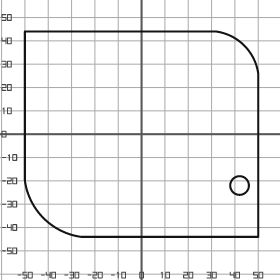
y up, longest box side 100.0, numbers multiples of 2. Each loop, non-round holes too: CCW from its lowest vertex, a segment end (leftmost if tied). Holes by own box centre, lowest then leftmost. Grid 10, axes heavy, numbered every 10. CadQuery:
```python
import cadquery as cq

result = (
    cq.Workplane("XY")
    .moveTo(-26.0, -44.0)
    .lineTo(50.0, -44.0)
    .lineTo(50.0, 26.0)
    .threePointArc((44.0, 38.0), (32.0, 44.0))
    .lineTo(-50.0, 44.0)
    .lineTo(-50.0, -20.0)
    .threePointArc((-42.0, -36.0), (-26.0, -44.0))
    .close()
    .moveTo(42.0, -22.0)
    .circle(4.0)
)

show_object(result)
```